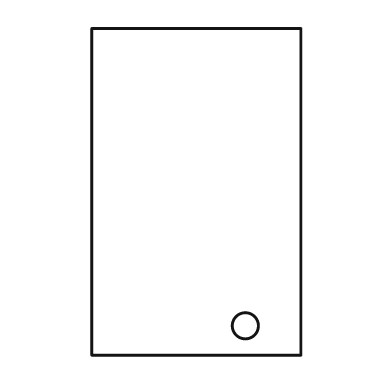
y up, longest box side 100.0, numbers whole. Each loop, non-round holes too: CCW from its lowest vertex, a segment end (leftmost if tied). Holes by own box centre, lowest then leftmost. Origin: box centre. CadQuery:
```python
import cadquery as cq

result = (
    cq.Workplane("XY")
    .moveTo(-32.0, -50.0)
    .lineTo(32.0, -50.0)
    .lineTo(32.0, 50.0)
    .lineTo(-32.0, 50.0)
    .close()
    .moveTo(15.0, -41.0)
    .circle(4.0)
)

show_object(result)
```